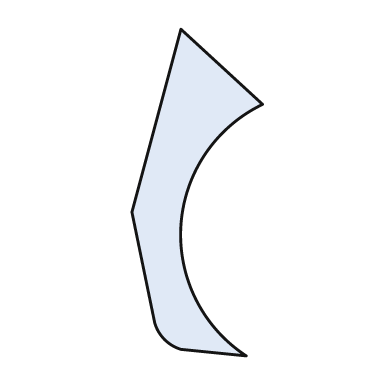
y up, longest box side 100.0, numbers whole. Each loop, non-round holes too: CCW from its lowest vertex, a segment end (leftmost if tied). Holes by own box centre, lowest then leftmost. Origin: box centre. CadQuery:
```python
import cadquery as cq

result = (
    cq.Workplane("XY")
    .moveTo(15.0, -50.0)
    .threePointArc((-5.0, -10.0), (20.0, 27.0))
    .lineTo(-5.0, 50.0)
    .lineTo(-20.0, -6.0)
    .lineTo(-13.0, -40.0)
    .threePointArc((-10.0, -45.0), (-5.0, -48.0))
    .close()
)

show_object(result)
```